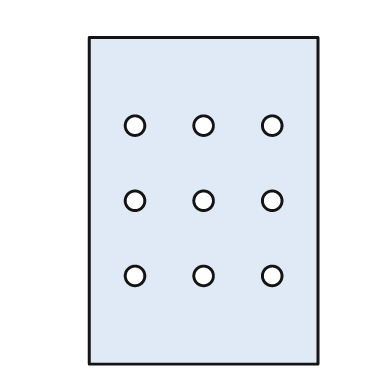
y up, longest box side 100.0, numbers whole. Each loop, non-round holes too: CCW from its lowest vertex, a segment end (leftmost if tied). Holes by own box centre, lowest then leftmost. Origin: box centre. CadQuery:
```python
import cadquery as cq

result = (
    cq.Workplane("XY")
    .moveTo(-35.0, -50.0)
    .lineTo(35.0, -50.0)
    .lineTo(35.0, 50.0)
    .lineTo(-35.0, 50.0)
    .close()
    .moveTo(-21.0, -23.0)
    .circle(3.0)
    .moveTo(0.0, -23.0)
    .circle(3.0)
    .moveTo(21.0, -23.0)
    .circle(3.0)
    .moveTo(-21.0, 0.0)
    .circle(3.0)
    .moveTo(0.0, 0.0)
    .circle(3.0)
    .moveTo(21.0, 0.0)
    .circle(3.0)
    .moveTo(-21.0, 23.0)
    .circle(3.0)
    .moveTo(0.0, 23.0)
    .circle(3.0)
    .moveTo(21.0, 23.0)
    .circle(3.0)
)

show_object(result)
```